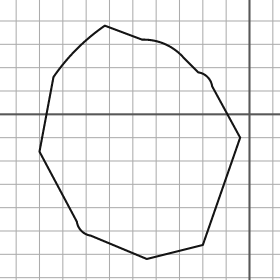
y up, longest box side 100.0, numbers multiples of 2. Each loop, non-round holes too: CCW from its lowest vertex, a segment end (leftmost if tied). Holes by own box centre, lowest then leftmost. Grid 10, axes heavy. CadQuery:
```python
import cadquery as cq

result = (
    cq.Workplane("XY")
    .moveTo(-44.0, -62.0)
    .lineTo(-20.0, -56.0)
    .lineTo(-4.0, -10.0)
    .lineTo(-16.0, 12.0)
    .threePointArc((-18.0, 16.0), (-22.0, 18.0))
    .lineTo(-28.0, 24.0)
    .threePointArc((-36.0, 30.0), (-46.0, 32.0))
    .lineTo(-62.0, 38.0)
    .threePointArc((-74.0, 28.0), (-84.0, 16.0))
    .lineTo(-90.0, -16.0)
    .lineTo(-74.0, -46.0)
    .threePointArc((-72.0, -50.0), (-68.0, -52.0))
    .close()
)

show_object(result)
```